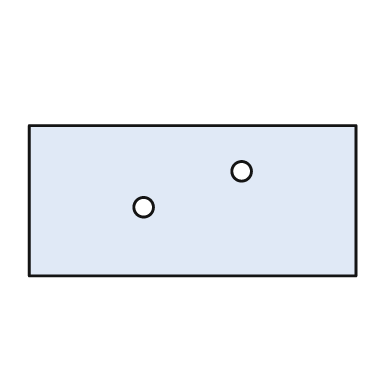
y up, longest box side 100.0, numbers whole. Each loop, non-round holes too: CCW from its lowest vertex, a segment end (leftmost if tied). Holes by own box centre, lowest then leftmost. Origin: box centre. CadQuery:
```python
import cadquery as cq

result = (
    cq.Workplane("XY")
    .moveTo(-50.0, -23.0)
    .lineTo(50.0, -23.0)
    .lineTo(50.0, 23.0)
    .lineTo(-50.0, 23.0)
    .close()
    .moveTo(-15.0, -2.0)
    .circle(3.0)
    .moveTo(15.0, 9.0)
    .circle(3.0)
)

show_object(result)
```